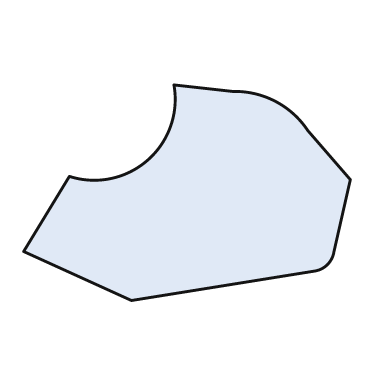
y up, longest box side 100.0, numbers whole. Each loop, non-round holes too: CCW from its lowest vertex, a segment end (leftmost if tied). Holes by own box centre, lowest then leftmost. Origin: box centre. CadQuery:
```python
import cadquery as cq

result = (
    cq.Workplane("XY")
    .moveTo(-17.0, -33.0)
    .lineTo(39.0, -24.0)
    .threePointArc((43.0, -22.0), (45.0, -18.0))
    .lineTo(50.0, 4.0)
    .lineTo(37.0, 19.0)
    .threePointArc((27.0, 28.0), (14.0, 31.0))
    .lineTo(-4.0, 33.0)
    .threePointArc((-12.0, 10.0), (-36.0, 5.0))
    .lineTo(-50.0, -18.0)
    .close()
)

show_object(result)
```